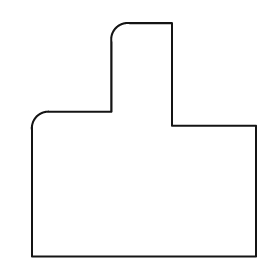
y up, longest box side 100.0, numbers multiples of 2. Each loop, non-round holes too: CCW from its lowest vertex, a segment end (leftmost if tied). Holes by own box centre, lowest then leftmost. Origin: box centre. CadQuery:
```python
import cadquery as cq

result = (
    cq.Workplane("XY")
    .moveTo(-48.0, -50.0)
    .lineTo(48.0, -50.0)
    .lineTo(48.0, 6.0)
    .lineTo(12.0, 6.0)
    .lineTo(12.0, 50.0)
    .lineTo(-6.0, 50.0)
    .threePointArc((-12.0, 48.0), (-14.0, 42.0))
    .lineTo(-14.0, 12.0)
    .lineTo(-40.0, 12.0)
    .threePointArc((-46.0, 10.0), (-48.0, 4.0))
    .close()
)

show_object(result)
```